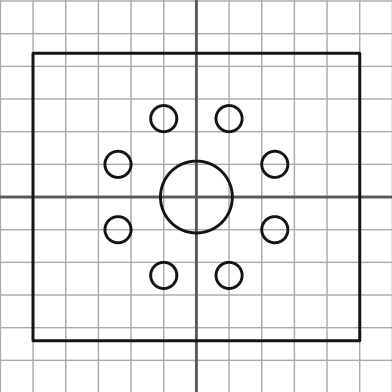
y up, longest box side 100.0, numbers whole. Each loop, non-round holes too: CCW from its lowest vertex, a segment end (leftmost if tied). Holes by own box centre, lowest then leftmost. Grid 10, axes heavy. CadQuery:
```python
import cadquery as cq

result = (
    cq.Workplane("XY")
    .moveTo(-50.0, -44.0)
    .lineTo(50.0, -44.0)
    .lineTo(50.0, 44.0)
    .lineTo(-50.0, 44.0)
    .close()
    .moveTo(-10.0, -24.0)
    .circle(4.0)
    .moveTo(10.0, -24.0)
    .circle(4.0)
    .moveTo(-24.0, -10.0)
    .circle(4.0)
    .moveTo(24.0, -10.0)
    .circle(4.0)
    .moveTo(0.0, 0.0)
    .circle(11.0)
    .moveTo(-24.0, 10.0)
    .circle(4.0)
    .moveTo(24.0, 10.0)
    .circle(4.0)
    .moveTo(-10.0, 24.0)
    .circle(4.0)
    .moveTo(10.0, 24.0)
    .circle(4.0)
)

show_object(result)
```